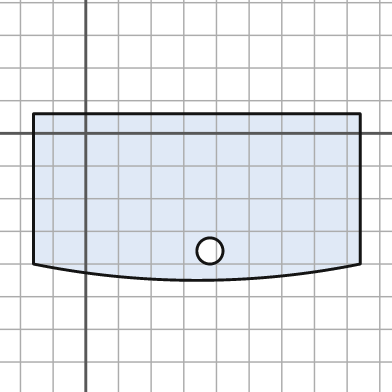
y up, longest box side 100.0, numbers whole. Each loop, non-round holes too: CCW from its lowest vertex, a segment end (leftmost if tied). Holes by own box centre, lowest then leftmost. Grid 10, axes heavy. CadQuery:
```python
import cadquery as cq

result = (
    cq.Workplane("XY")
    .moveTo(-16.0, -40.0)
    .threePointArc((34.0, -45.0), (84.0, -40.0))
    .lineTo(84.0, 6.0)
    .lineTo(-16.0, 6.0)
    .close()
    .moveTo(38.0, -36.0)
    .circle(4.0)
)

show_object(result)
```